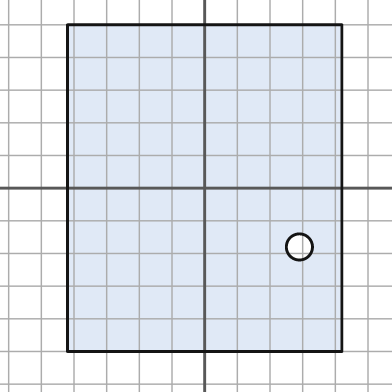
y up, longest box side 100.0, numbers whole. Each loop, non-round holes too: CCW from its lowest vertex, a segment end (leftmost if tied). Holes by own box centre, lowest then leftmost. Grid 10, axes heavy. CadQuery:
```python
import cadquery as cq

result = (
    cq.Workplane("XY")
    .moveTo(-42.0, -50.0)
    .lineTo(42.0, -50.0)
    .lineTo(42.0, 50.0)
    .lineTo(-42.0, 50.0)
    .close()
    .moveTo(29.0, -18.0)
    .circle(4.0)
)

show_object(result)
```